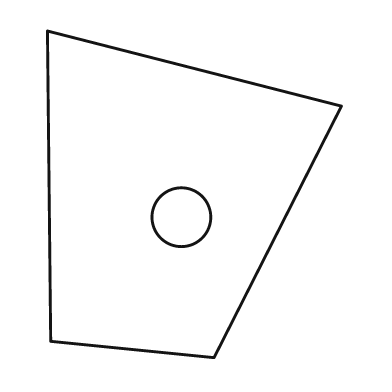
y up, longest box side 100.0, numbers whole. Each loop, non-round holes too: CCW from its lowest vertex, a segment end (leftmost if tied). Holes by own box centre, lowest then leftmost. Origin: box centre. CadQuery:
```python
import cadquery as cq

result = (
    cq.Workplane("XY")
    .moveTo(6.0, -50.0)
    .lineTo(45.0, 27.0)
    .lineTo(-45.0, 50.0)
    .lineTo(-44.0, -45.0)
    .close()
    .moveTo(-4.0, -7.0)
    .circle(9.0)
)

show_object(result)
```